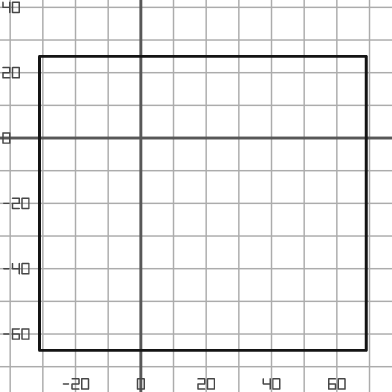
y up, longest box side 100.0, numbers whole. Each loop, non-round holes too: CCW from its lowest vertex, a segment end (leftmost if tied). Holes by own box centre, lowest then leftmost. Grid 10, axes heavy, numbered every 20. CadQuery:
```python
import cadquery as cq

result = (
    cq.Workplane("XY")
    .moveTo(-31.0, -65.0)
    .lineTo(69.0, -65.0)
    .lineTo(69.0, 25.0)
    .lineTo(-31.0, 25.0)
    .close()
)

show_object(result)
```